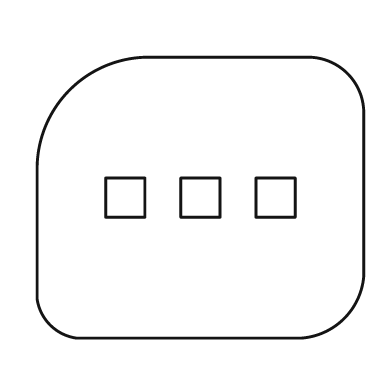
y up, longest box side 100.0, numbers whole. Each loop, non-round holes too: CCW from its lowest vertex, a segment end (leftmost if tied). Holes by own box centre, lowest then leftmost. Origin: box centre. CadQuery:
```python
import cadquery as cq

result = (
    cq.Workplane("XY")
    .moveTo(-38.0, -43.0)
    .lineTo(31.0, -43.0)
    .threePointArc((44.0, -37.0), (50.0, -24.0))
    .lineTo(50.0, 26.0)
    .threePointArc((45.0, 38.0), (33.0, 43.0))
    .lineTo(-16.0, 43.0)
    .threePointArc((-40.0, 33.0), (-50.0, 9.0))
    .lineTo(-50.0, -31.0)
    .threePointArc((-46.0, -39.0), (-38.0, -43.0))
    .close()
    .moveTo(-29.0, -6.0)
    .lineTo(-17.0, -6.0)
    .lineTo(-17.0, 6.0)
    .lineTo(-29.0, 6.0)
    .close()
    .moveTo(-6.0, -6.0)
    .lineTo(6.0, -6.0)
    .lineTo(6.0, 6.0)
    .lineTo(-6.0, 6.0)
    .close()
    .moveTo(17.0, -6.0)
    .lineTo(29.0, -6.0)
    .lineTo(29.0, 6.0)
    .lineTo(17.0, 6.0)
    .close()
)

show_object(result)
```